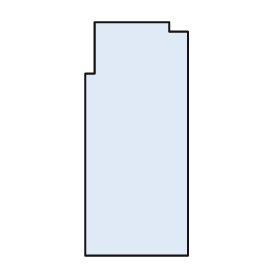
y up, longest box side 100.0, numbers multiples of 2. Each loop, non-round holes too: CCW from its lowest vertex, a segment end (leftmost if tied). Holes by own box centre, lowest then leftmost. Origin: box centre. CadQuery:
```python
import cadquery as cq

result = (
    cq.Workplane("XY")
    .moveTo(-22.0, -50.0)
    .lineTo(22.0, -50.0)
    .lineTo(22.0, 46.0)
    .lineTo(14.0, 46.0)
    .lineTo(14.0, 50.0)
    .lineTo(-18.0, 50.0)
    .lineTo(-18.0, 28.0)
    .lineTo(-22.0, 28.0)
    .close()
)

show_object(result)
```